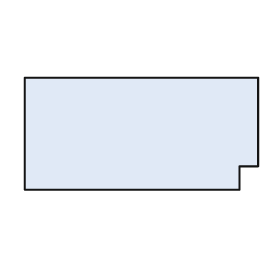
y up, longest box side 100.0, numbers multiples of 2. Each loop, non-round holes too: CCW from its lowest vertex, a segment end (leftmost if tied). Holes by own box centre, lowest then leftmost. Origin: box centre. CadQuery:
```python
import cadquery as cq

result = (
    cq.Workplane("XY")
    .moveTo(-50.0, -24.0)
    .lineTo(42.0, -24.0)
    .lineTo(42.0, -14.0)
    .lineTo(50.0, -14.0)
    .lineTo(50.0, 24.0)
    .lineTo(-50.0, 24.0)
    .close()
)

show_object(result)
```